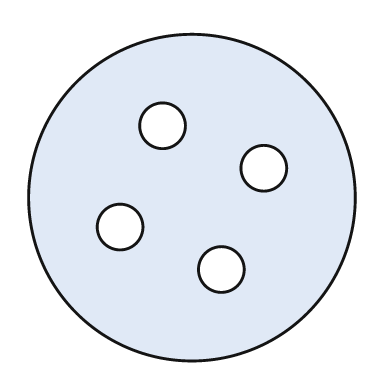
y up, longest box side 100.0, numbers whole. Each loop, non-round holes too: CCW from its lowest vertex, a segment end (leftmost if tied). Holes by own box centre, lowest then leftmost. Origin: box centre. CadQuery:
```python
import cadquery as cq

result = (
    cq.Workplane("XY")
    .moveTo(0.0, 0.0)
    .circle(50.0)
    .moveTo(9.0, -22.0)
    .circle(7.0)
    .moveTo(-22.0, -9.0)
    .circle(7.0)
    .moveTo(22.0, 9.0)
    .circle(7.0)
    .moveTo(-9.0, 22.0)
    .circle(7.0)
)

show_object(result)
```